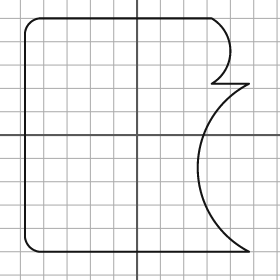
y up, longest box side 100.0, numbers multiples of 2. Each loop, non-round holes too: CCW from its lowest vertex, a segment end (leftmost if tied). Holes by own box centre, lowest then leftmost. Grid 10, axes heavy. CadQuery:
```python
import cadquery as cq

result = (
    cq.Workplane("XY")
    .moveTo(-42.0, -50.0)
    .lineTo(48.0, -50.0)
    .threePointArc((26.0, -14.0), (48.0, 22.0))
    .lineTo(32.0, 22.0)
    .threePointArc((40.0, 36.0), (32.0, 50.0))
    .lineTo(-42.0, 50.0)
    .threePointArc((-46.0, 48.0), (-48.0, 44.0))
    .lineTo(-48.0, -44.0)
    .threePointArc((-46.0, -48.0), (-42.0, -50.0))
    .close()
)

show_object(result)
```